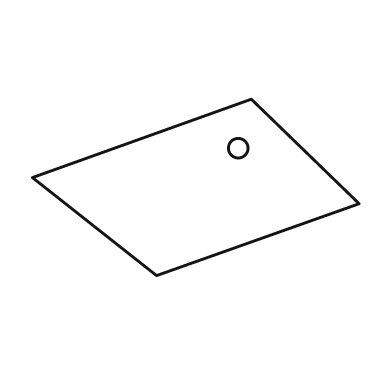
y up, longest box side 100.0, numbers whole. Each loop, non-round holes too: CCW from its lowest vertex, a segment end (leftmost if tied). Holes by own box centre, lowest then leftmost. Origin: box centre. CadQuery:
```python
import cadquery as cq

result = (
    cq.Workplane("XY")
    .moveTo(-12.0, -27.0)
    .lineTo(50.0, -5.0)
    .lineTo(17.0, 27.0)
    .lineTo(-50.0, 3.0)
    .close()
    .moveTo(13.0, 12.0)
    .circle(3.0)
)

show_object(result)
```